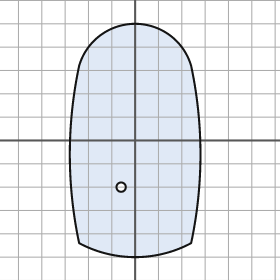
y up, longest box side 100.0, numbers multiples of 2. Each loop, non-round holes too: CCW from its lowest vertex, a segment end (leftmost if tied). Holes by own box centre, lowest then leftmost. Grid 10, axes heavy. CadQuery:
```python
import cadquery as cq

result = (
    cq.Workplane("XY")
    .moveTo(-24.0, -44.0)
    .threePointArc((0.0, -50.0), (24.0, -44.0))
    .threePointArc((28.0, -6.0), (24.0, 32.0))
    .threePointArc((0.0, 50.0), (-24.0, 32.0))
    .threePointArc((-28.0, -6.0), (-24.0, -44.0))
    .close()
    .moveTo(-6.0, -20.0)
    .circle(2.0)
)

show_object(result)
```